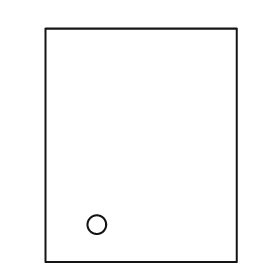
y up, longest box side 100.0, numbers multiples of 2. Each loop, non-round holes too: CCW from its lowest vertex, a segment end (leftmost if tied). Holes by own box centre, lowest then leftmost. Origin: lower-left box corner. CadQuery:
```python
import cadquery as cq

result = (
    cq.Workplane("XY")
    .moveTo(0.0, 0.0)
    .lineTo(82.0, 0.0)
    .lineTo(82.0, 100.0)
    .lineTo(0.0, 100.0)
    .close()
    .moveTo(22.0, 16.0)
    .circle(4.0)
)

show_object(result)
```